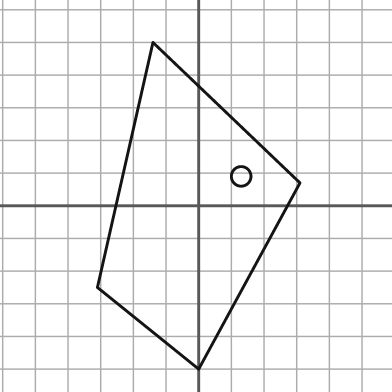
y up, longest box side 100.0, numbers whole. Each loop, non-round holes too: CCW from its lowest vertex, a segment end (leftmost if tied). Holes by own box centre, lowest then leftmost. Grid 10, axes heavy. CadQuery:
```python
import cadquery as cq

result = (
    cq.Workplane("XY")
    .moveTo(0.0, -50.0)
    .lineTo(31.0, 7.0)
    .lineTo(-14.0, 50.0)
    .lineTo(-31.0, -25.0)
    .close()
    .moveTo(13.0, 9.0)
    .circle(3.0)
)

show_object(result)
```